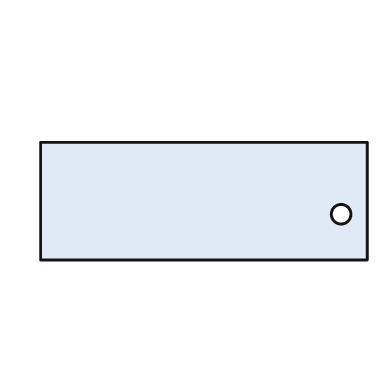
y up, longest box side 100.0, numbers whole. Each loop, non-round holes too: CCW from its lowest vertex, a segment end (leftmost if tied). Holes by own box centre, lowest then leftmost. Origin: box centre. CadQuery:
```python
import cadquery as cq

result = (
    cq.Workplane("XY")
    .moveTo(-50.0, -18.0)
    .lineTo(50.0, -18.0)
    .lineTo(50.0, 18.0)
    .lineTo(-50.0, 18.0)
    .close()
    .moveTo(42.0, -4.0)
    .circle(3.0)
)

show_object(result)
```